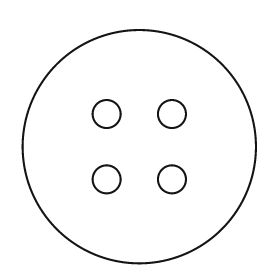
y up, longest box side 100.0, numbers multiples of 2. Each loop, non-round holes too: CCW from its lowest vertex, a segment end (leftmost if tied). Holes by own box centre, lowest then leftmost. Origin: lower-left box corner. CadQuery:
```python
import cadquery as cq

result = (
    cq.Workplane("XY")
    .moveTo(50.0, 50.0)
    .circle(50.0)
    .moveTo(36.0, 36.0)
    .circle(6.0)
    .moveTo(64.0, 36.0)
    .circle(6.0)
    .moveTo(36.0, 64.0)
    .circle(6.0)
    .moveTo(64.0, 64.0)
    .circle(6.0)
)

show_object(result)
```